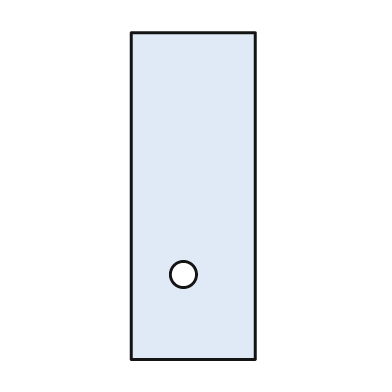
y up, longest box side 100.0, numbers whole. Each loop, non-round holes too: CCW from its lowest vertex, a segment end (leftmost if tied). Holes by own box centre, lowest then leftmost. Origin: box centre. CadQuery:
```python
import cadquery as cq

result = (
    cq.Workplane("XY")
    .moveTo(-19.0, -50.0)
    .lineTo(19.0, -50.0)
    .lineTo(19.0, 50.0)
    .lineTo(-19.0, 50.0)
    .close()
    .moveTo(-3.0, -24.0)
    .circle(4.0)
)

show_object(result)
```